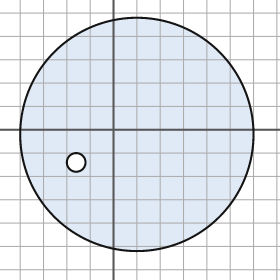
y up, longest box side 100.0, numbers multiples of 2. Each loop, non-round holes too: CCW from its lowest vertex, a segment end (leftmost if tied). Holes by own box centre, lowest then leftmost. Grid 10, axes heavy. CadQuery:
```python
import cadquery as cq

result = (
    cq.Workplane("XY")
    .moveTo(10.0, -2.0)
    .circle(50.0)
    .moveTo(-16.0, -14.0)
    .circle(4.0)
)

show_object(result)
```